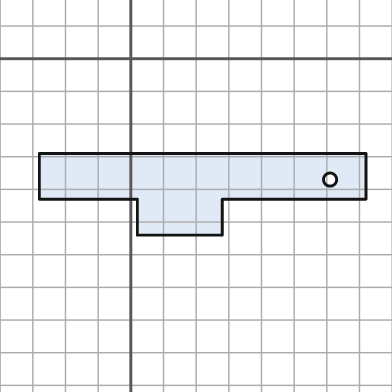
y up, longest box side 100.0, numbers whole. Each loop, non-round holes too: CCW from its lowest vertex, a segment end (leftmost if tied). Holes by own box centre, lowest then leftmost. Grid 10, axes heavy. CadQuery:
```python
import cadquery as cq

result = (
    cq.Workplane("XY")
    .moveTo(2.0, -54.0)
    .lineTo(28.0, -54.0)
    .lineTo(28.0, -43.0)
    .lineTo(72.0, -43.0)
    .lineTo(72.0, -29.0)
    .lineTo(-28.0, -29.0)
    .lineTo(-28.0, -43.0)
    .lineTo(2.0, -43.0)
    .close()
    .moveTo(61.0, -37.0)
    .circle(2.0)
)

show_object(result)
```